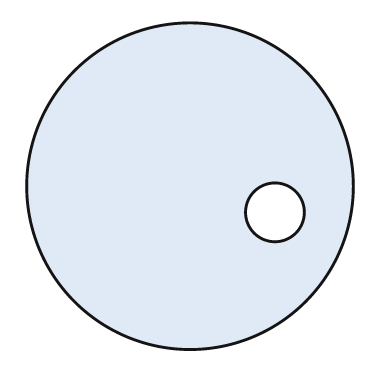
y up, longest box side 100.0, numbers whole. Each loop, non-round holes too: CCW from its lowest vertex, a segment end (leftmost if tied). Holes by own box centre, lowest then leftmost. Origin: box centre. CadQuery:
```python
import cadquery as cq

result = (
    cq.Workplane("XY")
    .moveTo(0.0, 0.0)
    .circle(50.0)
    .moveTo(26.0, -8.0)
    .circle(9.0)
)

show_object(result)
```